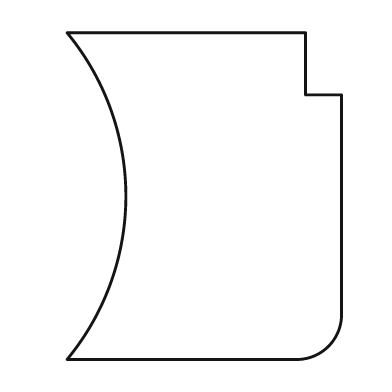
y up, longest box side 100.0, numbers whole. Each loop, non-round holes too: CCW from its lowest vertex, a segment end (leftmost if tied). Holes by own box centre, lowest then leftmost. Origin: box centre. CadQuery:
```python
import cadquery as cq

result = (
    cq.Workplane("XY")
    .moveTo(-42.0, -50.0)
    .lineTo(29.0, -50.0)
    .threePointArc((38.0, -46.0), (42.0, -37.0))
    .lineTo(42.0, 31.0)
    .lineTo(31.0, 31.0)
    .lineTo(31.0, 50.0)
    .lineTo(-42.0, 50.0)
    .threePointArc((-24.0, 0.0), (-42.0, -50.0))
    .close()
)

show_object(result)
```